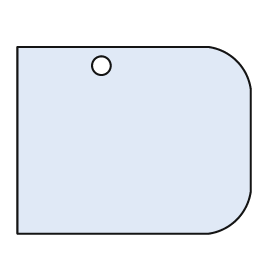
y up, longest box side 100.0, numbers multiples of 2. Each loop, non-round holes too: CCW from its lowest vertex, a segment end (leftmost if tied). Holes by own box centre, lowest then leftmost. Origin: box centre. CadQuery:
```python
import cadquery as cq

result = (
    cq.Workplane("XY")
    .moveTo(-50.0, -40.0)
    .lineTo(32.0, -40.0)
    .threePointArc((44.0, -34.0), (50.0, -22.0))
    .lineTo(50.0, 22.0)
    .threePointArc((44.0, 34.0), (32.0, 40.0))
    .lineTo(-50.0, 40.0)
    .close()
    .moveTo(-14.0, 32.0)
    .circle(4.0)
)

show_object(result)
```